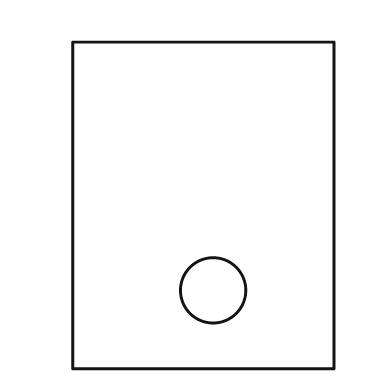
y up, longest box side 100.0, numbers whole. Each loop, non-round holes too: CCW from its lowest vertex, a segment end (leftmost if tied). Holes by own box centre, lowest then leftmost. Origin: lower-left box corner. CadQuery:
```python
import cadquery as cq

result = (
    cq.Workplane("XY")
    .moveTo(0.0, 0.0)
    .lineTo(80.0, 0.0)
    .lineTo(80.0, 100.0)
    .lineTo(0.0, 100.0)
    .close()
    .moveTo(43.0, 24.0)
    .circle(10.0)
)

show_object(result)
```